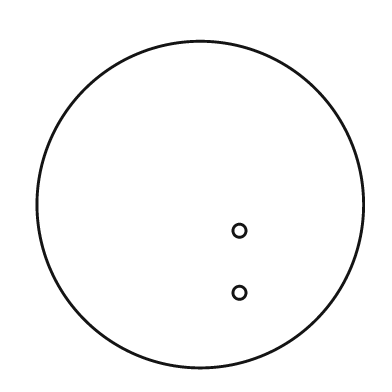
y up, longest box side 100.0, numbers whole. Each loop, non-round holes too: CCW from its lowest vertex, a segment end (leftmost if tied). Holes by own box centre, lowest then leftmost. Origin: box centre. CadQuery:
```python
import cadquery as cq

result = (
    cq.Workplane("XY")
    .moveTo(0.0, 0.0)
    .circle(50.0)
    .moveTo(12.0, -27.0)
    .circle(2.0)
    .moveTo(12.0, -8.0)
    .circle(2.0)
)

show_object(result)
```